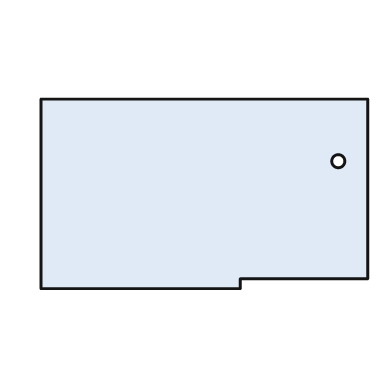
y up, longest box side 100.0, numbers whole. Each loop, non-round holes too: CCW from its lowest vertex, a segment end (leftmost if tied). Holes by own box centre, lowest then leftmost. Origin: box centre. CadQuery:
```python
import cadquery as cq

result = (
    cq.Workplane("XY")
    .moveTo(-50.0, -29.0)
    .lineTo(11.0, -29.0)
    .lineTo(11.0, -26.0)
    .lineTo(50.0, -26.0)
    .lineTo(50.0, 29.0)
    .lineTo(-50.0, 29.0)
    .close()
    .moveTo(41.0, 10.0)
    .circle(2.0)
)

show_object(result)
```